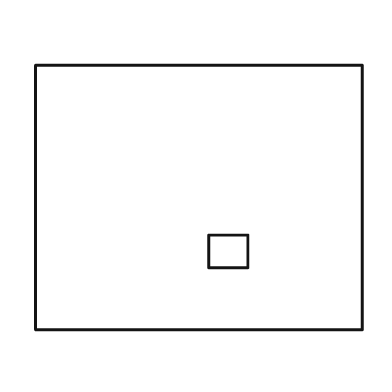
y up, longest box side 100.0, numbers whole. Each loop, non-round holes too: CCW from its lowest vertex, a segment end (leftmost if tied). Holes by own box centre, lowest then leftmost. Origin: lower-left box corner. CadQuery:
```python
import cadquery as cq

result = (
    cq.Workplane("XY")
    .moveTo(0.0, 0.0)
    .lineTo(100.0, 0.0)
    .lineTo(100.0, 81.0)
    .lineTo(0.0, 81.0)
    .close()
    .moveTo(53.0, 19.0)
    .lineTo(65.0, 19.0)
    .lineTo(65.0, 29.0)
    .lineTo(53.0, 29.0)
    .close()
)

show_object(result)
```